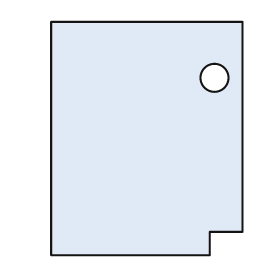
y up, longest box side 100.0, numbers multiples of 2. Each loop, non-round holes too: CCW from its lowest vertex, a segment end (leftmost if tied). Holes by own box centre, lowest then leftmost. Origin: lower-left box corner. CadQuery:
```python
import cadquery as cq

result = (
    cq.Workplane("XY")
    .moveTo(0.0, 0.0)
    .lineTo(68.0, 0.0)
    .lineTo(68.0, 10.0)
    .lineTo(82.0, 10.0)
    .lineTo(82.0, 100.0)
    .lineTo(0.0, 100.0)
    .close()
    .moveTo(70.0, 76.0)
    .circle(6.0)
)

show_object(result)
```